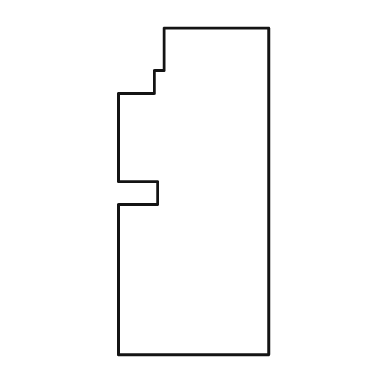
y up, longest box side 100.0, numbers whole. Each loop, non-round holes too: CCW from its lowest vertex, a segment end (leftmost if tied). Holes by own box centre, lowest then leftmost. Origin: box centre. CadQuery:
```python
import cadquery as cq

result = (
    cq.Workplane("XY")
    .moveTo(-23.0, -50.0)
    .lineTo(23.0, -50.0)
    .lineTo(23.0, 50.0)
    .lineTo(-9.0, 50.0)
    .lineTo(-9.0, 37.0)
    .lineTo(-12.0, 37.0)
    .lineTo(-12.0, 30.0)
    .lineTo(-23.0, 30.0)
    .lineTo(-23.0, 3.0)
    .lineTo(-11.0, 3.0)
    .lineTo(-11.0, -4.0)
    .lineTo(-23.0, -4.0)
    .close()
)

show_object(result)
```